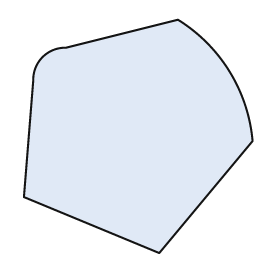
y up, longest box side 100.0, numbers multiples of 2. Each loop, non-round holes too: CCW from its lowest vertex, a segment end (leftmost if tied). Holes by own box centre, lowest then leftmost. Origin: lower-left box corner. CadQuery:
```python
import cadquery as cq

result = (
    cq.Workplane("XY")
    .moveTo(58.0, 0.0)
    .lineTo(98.0, 48.0)
    .threePointArc((88.0, 78.0), (66.0, 100.0))
    .lineTo(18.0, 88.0)
    .threePointArc((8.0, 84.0), (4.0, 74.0))
    .lineTo(0.0, 24.0)
    .close()
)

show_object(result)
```